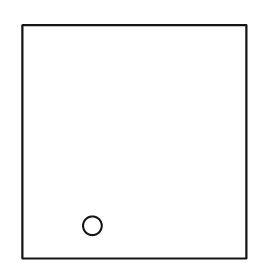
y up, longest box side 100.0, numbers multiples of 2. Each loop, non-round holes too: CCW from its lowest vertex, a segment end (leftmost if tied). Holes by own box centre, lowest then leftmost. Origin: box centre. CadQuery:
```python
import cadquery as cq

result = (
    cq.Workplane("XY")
    .moveTo(-48.0, -50.0)
    .lineTo(48.0, -50.0)
    .lineTo(48.0, 50.0)
    .lineTo(-48.0, 50.0)
    .close()
    .moveTo(-18.0, -36.0)
    .circle(4.0)
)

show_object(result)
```